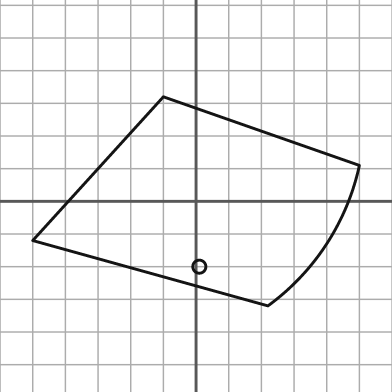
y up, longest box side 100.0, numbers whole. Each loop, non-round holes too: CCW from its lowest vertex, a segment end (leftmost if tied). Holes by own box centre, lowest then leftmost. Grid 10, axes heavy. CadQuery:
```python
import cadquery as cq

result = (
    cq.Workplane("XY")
    .moveTo(22.0, -32.0)
    .threePointArc((40.0, -13.0), (50.0, 11.0))
    .lineTo(-10.0, 32.0)
    .lineTo(-50.0, -12.0)
    .close()
    .moveTo(1.0, -20.0)
    .circle(2.0)
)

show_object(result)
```